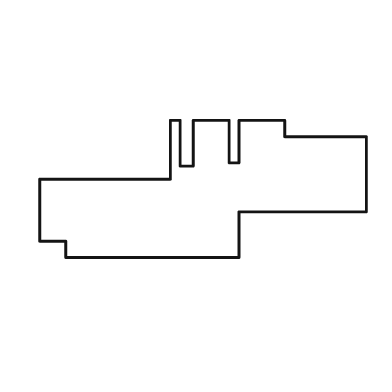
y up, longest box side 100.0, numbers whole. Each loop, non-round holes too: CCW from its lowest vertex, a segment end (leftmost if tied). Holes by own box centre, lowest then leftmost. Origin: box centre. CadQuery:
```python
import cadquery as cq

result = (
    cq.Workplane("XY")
    .moveTo(-42.0, -21.0)
    .lineTo(11.0, -21.0)
    .lineTo(11.0, -7.0)
    .lineTo(50.0, -7.0)
    .lineTo(50.0, 16.0)
    .lineTo(25.0, 16.0)
    .lineTo(25.0, 21.0)
    .lineTo(11.0, 21.0)
    .lineTo(11.0, 8.0)
    .lineTo(8.0, 8.0)
    .lineTo(8.0, 21.0)
    .lineTo(-3.0, 21.0)
    .lineTo(-3.0, 7.0)
    .lineTo(-7.0, 7.0)
    .lineTo(-7.0, 21.0)
    .lineTo(-10.0, 21.0)
    .lineTo(-10.0, 3.0)
    .lineTo(-50.0, 3.0)
    .lineTo(-50.0, -16.0)
    .lineTo(-42.0, -16.0)
    .close()
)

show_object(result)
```